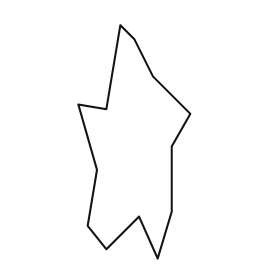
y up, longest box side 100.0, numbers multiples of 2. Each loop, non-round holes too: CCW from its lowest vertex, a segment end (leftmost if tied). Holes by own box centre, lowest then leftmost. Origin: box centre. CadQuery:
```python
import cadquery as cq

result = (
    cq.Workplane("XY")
    .moveTo(10.0, -50.0)
    .lineTo(16.0, -30.0)
    .lineTo(16.0, -2.0)
    .lineTo(24.0, 12.0)
    .lineTo(8.0, 28.0)
    .lineTo(0.0, 44.0)
    .lineTo(-6.0, 50.0)
    .lineTo(-12.0, 14.0)
    .lineTo(-24.0, 16.0)
    .lineTo(-16.0, -12.0)
    .lineTo(-20.0, -36.0)
    .lineTo(-12.0, -46.0)
    .lineTo(2.0, -32.0)
    .close()
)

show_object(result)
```